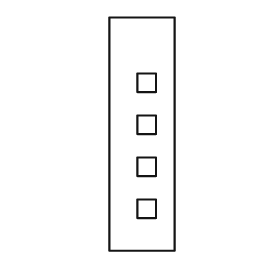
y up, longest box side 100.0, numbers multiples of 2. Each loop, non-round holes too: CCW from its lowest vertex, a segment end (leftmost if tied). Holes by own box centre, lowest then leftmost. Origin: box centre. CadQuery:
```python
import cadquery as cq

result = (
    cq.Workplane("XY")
    .moveTo(-14.0, -50.0)
    .lineTo(14.0, -50.0)
    .lineTo(14.0, 50.0)
    .lineTo(-14.0, 50.0)
    .close()
    .moveTo(-2.0, -36.0)
    .lineTo(6.0, -36.0)
    .lineTo(6.0, -28.0)
    .lineTo(-2.0, -28.0)
    .close()
    .moveTo(-2.0, -18.0)
    .lineTo(6.0, -18.0)
    .lineTo(6.0, -10.0)
    .lineTo(-2.0, -10.0)
    .close()
    .moveTo(-2.0, 0.0)
    .lineTo(6.0, 0.0)
    .lineTo(6.0, 8.0)
    .lineTo(-2.0, 8.0)
    .close()
    .moveTo(-2.0, 18.0)
    .lineTo(6.0, 18.0)
    .lineTo(6.0, 26.0)
    .lineTo(-2.0, 26.0)
    .close()
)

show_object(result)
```